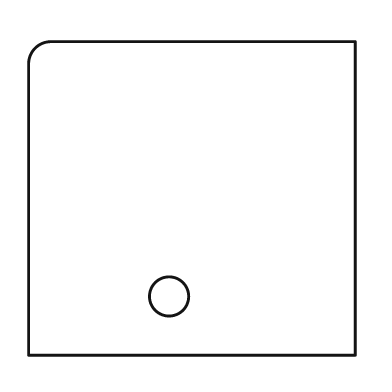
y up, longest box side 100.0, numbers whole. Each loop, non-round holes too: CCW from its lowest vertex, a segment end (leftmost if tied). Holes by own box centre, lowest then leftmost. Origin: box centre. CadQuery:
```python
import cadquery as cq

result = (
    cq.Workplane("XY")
    .moveTo(-50.0, -48.0)
    .lineTo(50.0, -48.0)
    .lineTo(50.0, 48.0)
    .lineTo(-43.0, 48.0)
    .threePointArc((-48.0, 46.0), (-50.0, 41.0))
    .close()
    .moveTo(-7.0, -30.0)
    .circle(6.0)
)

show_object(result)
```